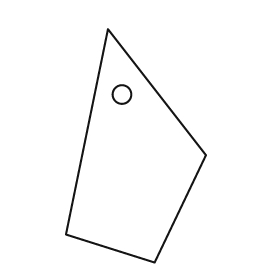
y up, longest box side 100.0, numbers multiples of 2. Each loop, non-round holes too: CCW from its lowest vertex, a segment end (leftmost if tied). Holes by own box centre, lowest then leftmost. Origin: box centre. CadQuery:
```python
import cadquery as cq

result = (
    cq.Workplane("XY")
    .moveTo(8.0, -50.0)
    .lineTo(30.0, -4.0)
    .lineTo(-12.0, 50.0)
    .lineTo(-30.0, -38.0)
    .close()
    .moveTo(-6.0, 22.0)
    .circle(4.0)
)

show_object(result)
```